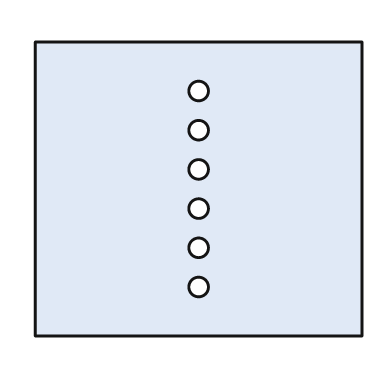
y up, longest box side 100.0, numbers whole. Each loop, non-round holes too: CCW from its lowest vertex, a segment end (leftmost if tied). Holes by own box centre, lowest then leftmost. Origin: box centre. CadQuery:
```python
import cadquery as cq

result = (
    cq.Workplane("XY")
    .moveTo(-50.0, -45.0)
    .lineTo(50.0, -45.0)
    .lineTo(50.0, 45.0)
    .lineTo(-50.0, 45.0)
    .close()
    .moveTo(0.0, -30.0)
    .circle(3.0)
    .moveTo(0.0, -18.0)
    .circle(3.0)
    .moveTo(0.0, -6.0)
    .circle(3.0)
    .moveTo(0.0, 6.0)
    .circle(3.0)
    .moveTo(0.0, 18.0)
    .circle(3.0)
    .moveTo(0.0, 30.0)
    .circle(3.0)
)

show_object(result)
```